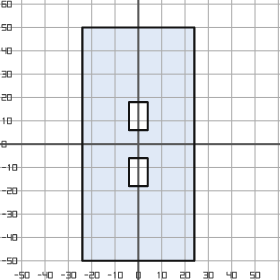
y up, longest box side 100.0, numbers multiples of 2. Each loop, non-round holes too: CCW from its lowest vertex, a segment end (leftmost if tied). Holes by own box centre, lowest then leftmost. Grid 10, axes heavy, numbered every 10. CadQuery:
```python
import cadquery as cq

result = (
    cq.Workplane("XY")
    .moveTo(-24.0, -50.0)
    .lineTo(24.0, -50.0)
    .lineTo(24.0, 50.0)
    .lineTo(-24.0, 50.0)
    .close()
    .moveTo(-4.0, -18.0)
    .lineTo(4.0, -18.0)
    .lineTo(4.0, -6.0)
    .lineTo(-4.0, -6.0)
    .close()
    .moveTo(-4.0, 6.0)
    .lineTo(4.0, 6.0)
    .lineTo(4.0, 18.0)
    .lineTo(-4.0, 18.0)
    .close()
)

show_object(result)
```